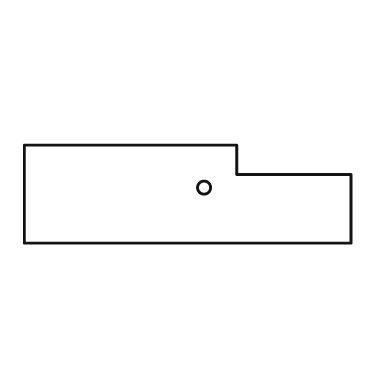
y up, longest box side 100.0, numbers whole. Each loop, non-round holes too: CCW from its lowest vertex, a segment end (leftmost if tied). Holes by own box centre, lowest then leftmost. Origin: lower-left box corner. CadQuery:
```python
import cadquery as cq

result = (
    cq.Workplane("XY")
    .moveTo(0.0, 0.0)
    .lineTo(100.0, 0.0)
    .lineTo(100.0, 21.0)
    .lineTo(65.0, 21.0)
    .lineTo(65.0, 30.0)
    .lineTo(0.0, 30.0)
    .close()
    .moveTo(55.0, 17.0)
    .circle(2.0)
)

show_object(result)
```